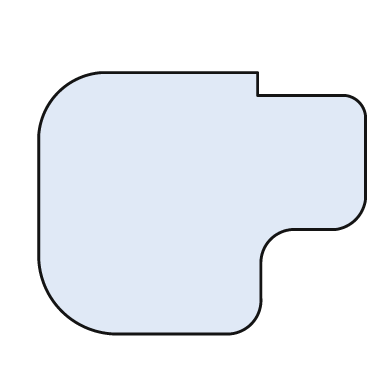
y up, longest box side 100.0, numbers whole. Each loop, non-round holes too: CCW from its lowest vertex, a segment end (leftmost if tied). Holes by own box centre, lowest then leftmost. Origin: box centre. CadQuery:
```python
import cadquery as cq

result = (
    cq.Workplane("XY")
    .moveTo(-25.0, -40.0)
    .lineTo(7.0, -40.0)
    .threePointArc((15.0, -37.0), (18.0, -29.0))
    .lineTo(18.0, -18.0)
    .threePointArc((21.0, -11.0), (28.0, -8.0))
    .lineTo(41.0, -8.0)
    .threePointArc((47.0, -5.0), (50.0, 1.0))
    .lineTo(50.0, 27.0)
    .threePointArc((48.0, 31.0), (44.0, 33.0))
    .lineTo(17.0, 33.0)
    .lineTo(17.0, 40.0)
    .lineTo(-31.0, 40.0)
    .threePointArc((-44.0, 34.0), (-50.0, 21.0))
    .lineTo(-50.0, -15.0)
    .threePointArc((-43.0, -33.0), (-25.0, -40.0))
    .close()
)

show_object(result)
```